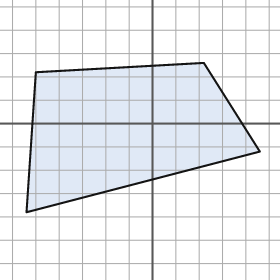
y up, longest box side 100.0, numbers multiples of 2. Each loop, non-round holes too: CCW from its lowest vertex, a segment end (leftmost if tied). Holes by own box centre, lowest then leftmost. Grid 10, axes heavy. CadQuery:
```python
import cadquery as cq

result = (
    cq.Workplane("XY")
    .moveTo(-54.0, -38.0)
    .lineTo(46.0, -12.0)
    .lineTo(22.0, 26.0)
    .lineTo(-50.0, 22.0)
    .close()
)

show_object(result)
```